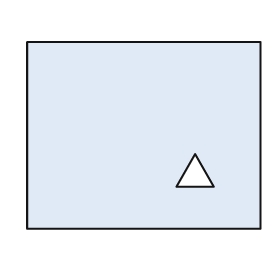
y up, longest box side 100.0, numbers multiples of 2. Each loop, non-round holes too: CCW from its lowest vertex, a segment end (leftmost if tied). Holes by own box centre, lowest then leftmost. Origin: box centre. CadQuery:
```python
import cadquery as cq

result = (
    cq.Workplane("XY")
    .moveTo(-50.0, -40.0)
    .lineTo(50.0, -40.0)
    .lineTo(50.0, 40.0)
    .lineTo(-50.0, 40.0)
    .close()
    .moveTo(14.0, -22.0)
    .lineTo(30.0, -22.0)
    .lineTo(22.0, -8.0)
    .close()
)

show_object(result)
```